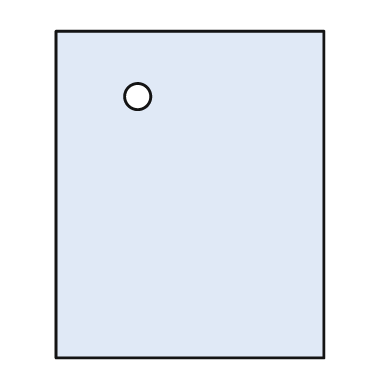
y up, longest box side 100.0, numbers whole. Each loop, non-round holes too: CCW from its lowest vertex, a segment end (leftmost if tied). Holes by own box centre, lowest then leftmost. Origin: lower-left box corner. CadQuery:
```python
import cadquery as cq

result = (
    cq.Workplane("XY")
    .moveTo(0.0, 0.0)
    .lineTo(82.0, 0.0)
    .lineTo(82.0, 100.0)
    .lineTo(0.0, 100.0)
    .close()
    .moveTo(25.0, 80.0)
    .circle(4.0)
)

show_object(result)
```